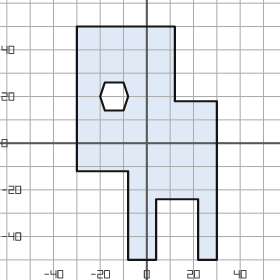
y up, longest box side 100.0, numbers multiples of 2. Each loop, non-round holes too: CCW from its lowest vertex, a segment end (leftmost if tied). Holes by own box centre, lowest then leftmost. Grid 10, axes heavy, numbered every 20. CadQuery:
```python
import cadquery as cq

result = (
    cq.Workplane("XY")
    .moveTo(-8.0, -50.0)
    .lineTo(4.0, -50.0)
    .lineTo(4.0, -24.0)
    .lineTo(22.0, -24.0)
    .lineTo(22.0, -50.0)
    .lineTo(30.0, -50.0)
    .lineTo(30.0, 18.0)
    .lineTo(12.0, 18.0)
    .lineTo(12.0, 50.0)
    .lineTo(-30.0, 50.0)
    .lineTo(-30.0, -12.0)
    .lineTo(-8.0, -12.0)
    .close()
    .moveTo(-18.0, 14.0)
    .lineTo(-10.0, 14.0)
    .lineTo(-8.0, 20.0)
    .lineTo(-10.0, 26.0)
    .lineTo(-18.0, 26.0)
    .lineTo(-20.0, 20.0)
    .close()
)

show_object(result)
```